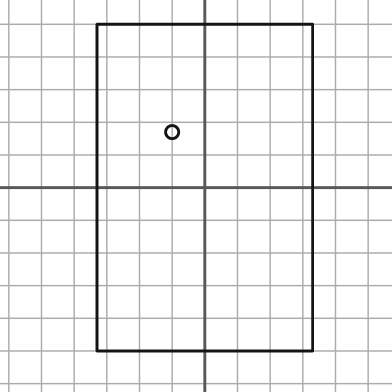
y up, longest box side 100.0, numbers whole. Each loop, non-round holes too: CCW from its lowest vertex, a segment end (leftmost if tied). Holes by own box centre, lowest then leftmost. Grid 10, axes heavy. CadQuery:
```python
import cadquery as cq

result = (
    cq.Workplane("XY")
    .moveTo(-33.0, -50.0)
    .lineTo(33.0, -50.0)
    .lineTo(33.0, 50.0)
    .lineTo(-33.0, 50.0)
    .close()
    .moveTo(-10.0, 17.0)
    .circle(2.0)
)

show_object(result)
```